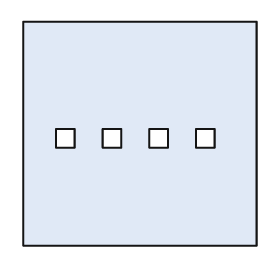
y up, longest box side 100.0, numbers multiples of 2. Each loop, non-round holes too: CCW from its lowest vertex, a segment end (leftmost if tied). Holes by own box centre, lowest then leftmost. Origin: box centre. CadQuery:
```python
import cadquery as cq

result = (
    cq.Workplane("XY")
    .moveTo(-50.0, -48.0)
    .lineTo(50.0, -48.0)
    .lineTo(50.0, 48.0)
    .lineTo(-50.0, 48.0)
    .close()
    .moveTo(-36.0, -6.0)
    .lineTo(-28.0, -6.0)
    .lineTo(-28.0, 2.0)
    .lineTo(-36.0, 2.0)
    .close()
    .moveTo(-16.0, -6.0)
    .lineTo(-8.0, -6.0)
    .lineTo(-8.0, 2.0)
    .lineTo(-16.0, 2.0)
    .close()
    .moveTo(4.0, -6.0)
    .lineTo(12.0, -6.0)
    .lineTo(12.0, 2.0)
    .lineTo(4.0, 2.0)
    .close()
    .moveTo(24.0, -6.0)
    .lineTo(32.0, -6.0)
    .lineTo(32.0, 2.0)
    .lineTo(24.0, 2.0)
    .close()
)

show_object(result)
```